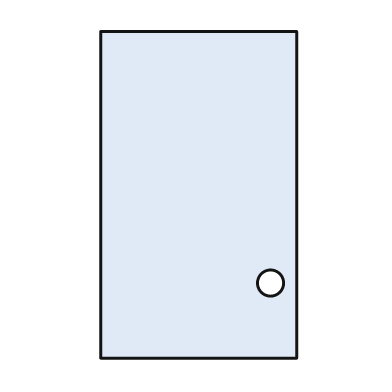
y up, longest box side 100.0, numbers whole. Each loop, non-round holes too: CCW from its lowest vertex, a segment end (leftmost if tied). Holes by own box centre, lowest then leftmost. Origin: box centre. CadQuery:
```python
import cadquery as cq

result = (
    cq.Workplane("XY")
    .moveTo(-30.0, -50.0)
    .lineTo(30.0, -50.0)
    .lineTo(30.0, 50.0)
    .lineTo(-30.0, 50.0)
    .close()
    .moveTo(22.0, -27.0)
    .circle(4.0)
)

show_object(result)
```